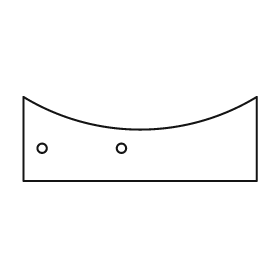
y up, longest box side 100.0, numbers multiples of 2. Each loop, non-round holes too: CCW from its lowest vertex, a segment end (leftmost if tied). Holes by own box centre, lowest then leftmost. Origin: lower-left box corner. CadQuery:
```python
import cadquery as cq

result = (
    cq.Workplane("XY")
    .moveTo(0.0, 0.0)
    .lineTo(100.0, 0.0)
    .lineTo(100.0, 36.0)
    .threePointArc((50.0, 22.0), (0.0, 36.0))
    .close()
    .moveTo(8.0, 14.0)
    .circle(2.0)
    .moveTo(42.0, 14.0)
    .circle(2.0)
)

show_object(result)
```